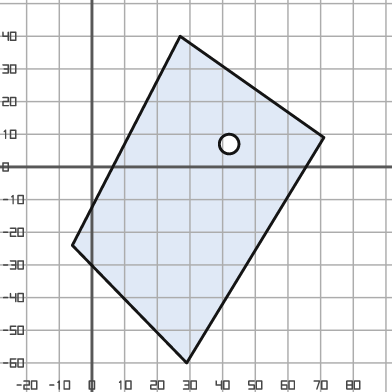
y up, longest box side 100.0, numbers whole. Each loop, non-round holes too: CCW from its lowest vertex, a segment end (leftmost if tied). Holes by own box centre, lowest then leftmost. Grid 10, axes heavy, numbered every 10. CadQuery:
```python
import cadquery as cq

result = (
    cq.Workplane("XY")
    .moveTo(29.0, -60.0)
    .lineTo(71.0, 9.0)
    .lineTo(27.0, 40.0)
    .lineTo(-6.0, -24.0)
    .close()
    .moveTo(42.0, 7.0)
    .circle(3.0)
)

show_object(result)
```